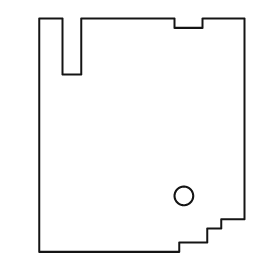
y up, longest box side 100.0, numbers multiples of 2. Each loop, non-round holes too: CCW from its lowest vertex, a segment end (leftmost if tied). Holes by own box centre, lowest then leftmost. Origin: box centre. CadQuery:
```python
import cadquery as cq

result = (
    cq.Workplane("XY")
    .moveTo(-44.0, -50.0)
    .lineTo(16.0, -50.0)
    .lineTo(16.0, -46.0)
    .lineTo(28.0, -46.0)
    .lineTo(28.0, -40.0)
    .lineTo(34.0, -40.0)
    .lineTo(34.0, -36.0)
    .lineTo(44.0, -36.0)
    .lineTo(44.0, 50.0)
    .lineTo(26.0, 50.0)
    .lineTo(26.0, 46.0)
    .lineTo(14.0, 46.0)
    .lineTo(14.0, 50.0)
    .lineTo(-26.0, 50.0)
    .lineTo(-26.0, 26.0)
    .lineTo(-34.0, 26.0)
    .lineTo(-34.0, 50.0)
    .lineTo(-44.0, 50.0)
    .close()
    .moveTo(18.0, -26.0)
    .circle(4.0)
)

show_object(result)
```